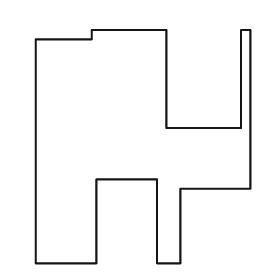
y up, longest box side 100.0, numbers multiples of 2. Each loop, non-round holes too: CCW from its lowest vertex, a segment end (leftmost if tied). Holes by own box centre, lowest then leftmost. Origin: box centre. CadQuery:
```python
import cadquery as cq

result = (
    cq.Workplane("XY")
    .moveTo(-46.0, -50.0)
    .lineTo(-20.0, -50.0)
    .lineTo(-20.0, -14.0)
    .lineTo(6.0, -14.0)
    .lineTo(6.0, -50.0)
    .lineTo(16.0, -50.0)
    .lineTo(16.0, -18.0)
    .lineTo(46.0, -18.0)
    .lineTo(46.0, 50.0)
    .lineTo(42.0, 50.0)
    .lineTo(42.0, 8.0)
    .lineTo(10.0, 8.0)
    .lineTo(10.0, 50.0)
    .lineTo(-22.0, 50.0)
    .lineTo(-22.0, 46.0)
    .lineTo(-46.0, 46.0)
    .close()
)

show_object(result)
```